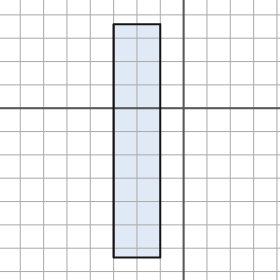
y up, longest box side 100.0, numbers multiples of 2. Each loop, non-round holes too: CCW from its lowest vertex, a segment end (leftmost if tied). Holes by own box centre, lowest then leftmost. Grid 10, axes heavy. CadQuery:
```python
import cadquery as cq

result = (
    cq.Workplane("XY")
    .moveTo(-30.0, -64.0)
    .lineTo(-10.0, -64.0)
    .lineTo(-10.0, 36.0)
    .lineTo(-30.0, 36.0)
    .close()
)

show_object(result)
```